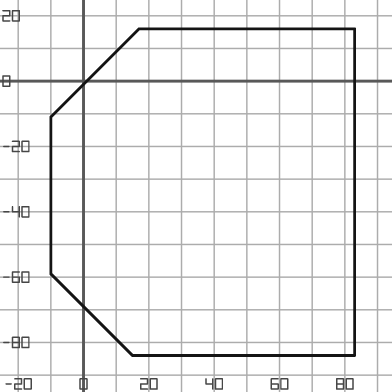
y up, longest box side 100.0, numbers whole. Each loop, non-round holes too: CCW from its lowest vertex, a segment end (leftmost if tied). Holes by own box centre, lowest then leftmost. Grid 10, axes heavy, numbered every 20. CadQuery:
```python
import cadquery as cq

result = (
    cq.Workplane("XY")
    .moveTo(15.0, -84.0)
    .lineTo(83.0, -84.0)
    .lineTo(83.0, 16.0)
    .lineTo(17.0, 16.0)
    .lineTo(-10.0, -11.0)
    .lineTo(-10.0, -59.0)
    .close()
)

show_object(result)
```